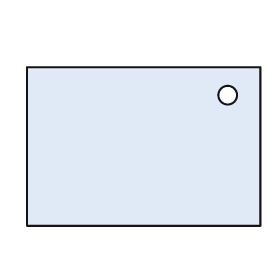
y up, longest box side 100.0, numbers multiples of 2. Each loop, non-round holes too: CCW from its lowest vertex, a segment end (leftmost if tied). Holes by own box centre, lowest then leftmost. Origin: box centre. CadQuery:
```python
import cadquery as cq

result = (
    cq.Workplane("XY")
    .moveTo(-50.0, -34.0)
    .lineTo(50.0, -34.0)
    .lineTo(50.0, 34.0)
    .lineTo(-50.0, 34.0)
    .close()
    .moveTo(36.0, 22.0)
    .circle(4.0)
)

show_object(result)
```